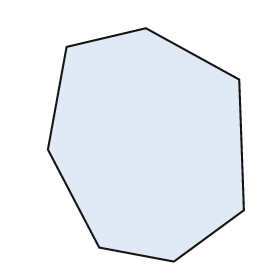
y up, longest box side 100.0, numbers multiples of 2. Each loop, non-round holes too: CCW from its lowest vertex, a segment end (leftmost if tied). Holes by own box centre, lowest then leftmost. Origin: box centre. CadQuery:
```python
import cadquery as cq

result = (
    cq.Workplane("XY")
    .moveTo(12.0, -50.0)
    .lineTo(42.0, -28.0)
    .lineTo(40.0, 28.0)
    .lineTo(0.0, 50.0)
    .lineTo(-34.0, 42.0)
    .lineTo(-42.0, -2.0)
    .lineTo(-20.0, -44.0)
    .close()
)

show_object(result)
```